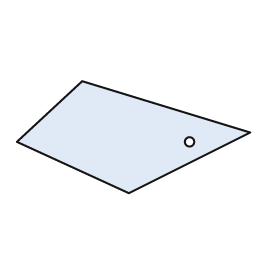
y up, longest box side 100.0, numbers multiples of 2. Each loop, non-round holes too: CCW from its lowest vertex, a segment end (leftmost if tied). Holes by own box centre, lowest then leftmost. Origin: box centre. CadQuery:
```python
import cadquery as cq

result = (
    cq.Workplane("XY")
    .moveTo(-2.0, -24.0)
    .lineTo(50.0, 2.0)
    .lineTo(-22.0, 24.0)
    .lineTo(-50.0, -2.0)
    .close()
    .moveTo(24.0, -2.0)
    .circle(2.0)
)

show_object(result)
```